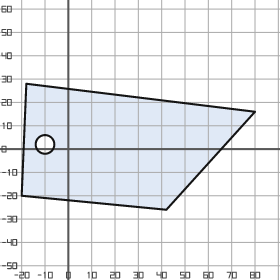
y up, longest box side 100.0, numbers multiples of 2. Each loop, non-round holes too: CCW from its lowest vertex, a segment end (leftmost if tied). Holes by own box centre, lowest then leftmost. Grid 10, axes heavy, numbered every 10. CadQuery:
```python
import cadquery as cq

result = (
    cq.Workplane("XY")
    .moveTo(42.0, -26.0)
    .lineTo(80.0, 16.0)
    .lineTo(-18.0, 28.0)
    .lineTo(-20.0, -20.0)
    .close()
    .moveTo(-10.0, 2.0)
    .circle(4.0)
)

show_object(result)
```